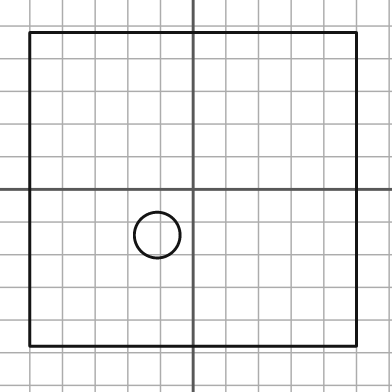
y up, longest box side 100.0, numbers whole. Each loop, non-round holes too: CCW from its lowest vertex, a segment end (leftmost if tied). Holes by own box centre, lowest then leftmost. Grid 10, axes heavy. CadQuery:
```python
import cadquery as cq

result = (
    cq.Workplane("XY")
    .moveTo(-50.0, -48.0)
    .lineTo(50.0, -48.0)
    .lineTo(50.0, 48.0)
    .lineTo(-50.0, 48.0)
    .close()
    .moveTo(-11.0, -14.0)
    .circle(7.0)
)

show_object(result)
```